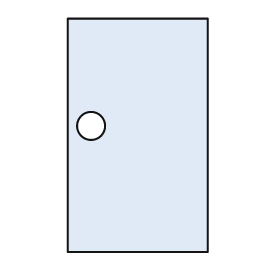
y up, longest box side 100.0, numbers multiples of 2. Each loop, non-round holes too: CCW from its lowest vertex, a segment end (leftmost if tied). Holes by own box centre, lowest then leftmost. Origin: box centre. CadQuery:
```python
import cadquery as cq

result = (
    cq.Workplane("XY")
    .moveTo(-30.0, -50.0)
    .lineTo(30.0, -50.0)
    .lineTo(30.0, 50.0)
    .lineTo(-30.0, 50.0)
    .close()
    .moveTo(-20.0, 4.0)
    .circle(6.0)
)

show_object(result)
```